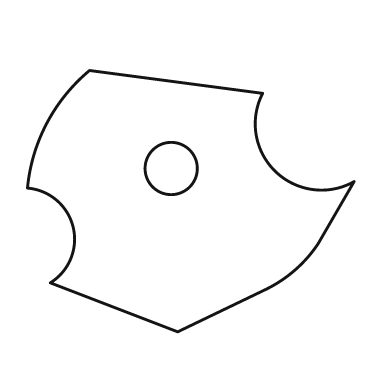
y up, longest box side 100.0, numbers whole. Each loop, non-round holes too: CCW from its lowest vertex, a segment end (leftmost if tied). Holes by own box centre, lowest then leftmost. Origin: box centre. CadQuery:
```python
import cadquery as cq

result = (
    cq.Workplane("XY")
    .moveTo(-4.0, -40.0)
    .lineTo(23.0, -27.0)
    .threePointArc((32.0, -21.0), (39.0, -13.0))
    .lineTo(50.0, 6.0)
    .threePointArc((26.0, 9.0), (22.0, 33.0))
    .lineTo(-31.0, 40.0)
    .threePointArc((-44.0, 24.0), (-50.0, 4.0))
    .threePointArc((-36.0, -8.0), (-43.0, -25.0))
    .close()
    .moveTo(-6.0, 10.0)
    .circle(8.0)
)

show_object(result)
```